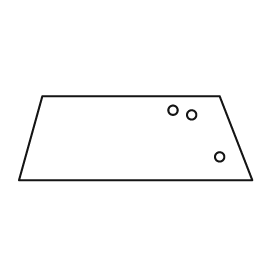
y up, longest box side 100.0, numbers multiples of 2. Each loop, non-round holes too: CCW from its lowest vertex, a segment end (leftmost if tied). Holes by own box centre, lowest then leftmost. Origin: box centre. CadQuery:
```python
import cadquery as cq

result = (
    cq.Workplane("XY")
    .moveTo(-50.0, -18.0)
    .lineTo(50.0, -18.0)
    .lineTo(36.0, 18.0)
    .lineTo(-40.0, 18.0)
    .close()
    .moveTo(36.0, -8.0)
    .circle(2.0)
    .moveTo(24.0, 10.0)
    .circle(2.0)
    .moveTo(16.0, 12.0)
    .circle(2.0)
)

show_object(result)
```